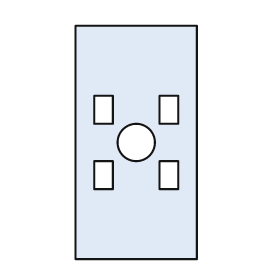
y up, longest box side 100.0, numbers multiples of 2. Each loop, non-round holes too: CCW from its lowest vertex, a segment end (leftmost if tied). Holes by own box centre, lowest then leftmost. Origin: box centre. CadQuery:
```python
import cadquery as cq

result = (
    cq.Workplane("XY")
    .moveTo(-26.0, -50.0)
    .lineTo(26.0, -50.0)
    .lineTo(26.0, 50.0)
    .lineTo(-26.0, 50.0)
    .close()
    .moveTo(-18.0, -20.0)
    .lineTo(-10.0, -20.0)
    .lineTo(-10.0, -8.0)
    .lineTo(-18.0, -8.0)
    .close()
    .moveTo(10.0, -20.0)
    .lineTo(18.0, -20.0)
    .lineTo(18.0, -8.0)
    .lineTo(10.0, -8.0)
    .close()
    .moveTo(0.0, 0.0)
    .circle(8.0)
    .moveTo(-18.0, 8.0)
    .lineTo(-10.0, 8.0)
    .lineTo(-10.0, 20.0)
    .lineTo(-18.0, 20.0)
    .close()
    .moveTo(10.0, 8.0)
    .lineTo(18.0, 8.0)
    .lineTo(18.0, 20.0)
    .lineTo(10.0, 20.0)
    .close()
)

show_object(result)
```